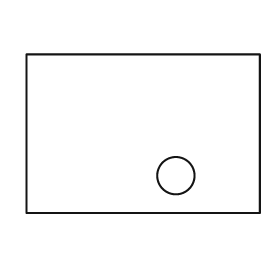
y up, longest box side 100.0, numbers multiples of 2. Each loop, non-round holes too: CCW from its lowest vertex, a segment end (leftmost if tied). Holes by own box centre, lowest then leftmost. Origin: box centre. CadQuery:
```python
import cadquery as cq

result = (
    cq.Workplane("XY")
    .moveTo(-50.0, -34.0)
    .lineTo(50.0, -34.0)
    .lineTo(50.0, 34.0)
    .lineTo(-50.0, 34.0)
    .close()
    .moveTo(14.0, -18.0)
    .circle(8.0)
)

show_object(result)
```